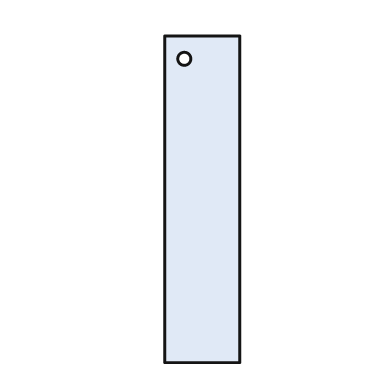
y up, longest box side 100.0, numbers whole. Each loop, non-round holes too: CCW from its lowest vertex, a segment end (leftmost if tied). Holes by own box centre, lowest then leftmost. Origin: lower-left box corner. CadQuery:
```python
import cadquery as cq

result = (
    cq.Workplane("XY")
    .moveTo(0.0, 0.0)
    .lineTo(23.0, 0.0)
    .lineTo(23.0, 100.0)
    .lineTo(0.0, 100.0)
    .close()
    .moveTo(6.0, 93.0)
    .circle(2.0)
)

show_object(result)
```